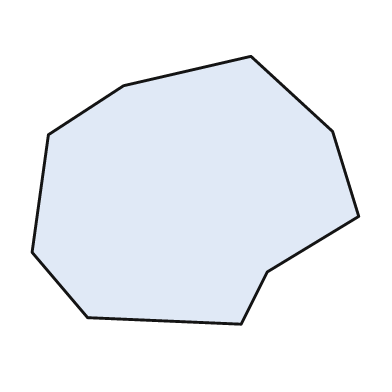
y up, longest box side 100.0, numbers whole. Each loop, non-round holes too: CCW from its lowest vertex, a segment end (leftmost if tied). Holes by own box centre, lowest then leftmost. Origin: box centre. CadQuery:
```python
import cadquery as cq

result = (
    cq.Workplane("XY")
    .moveTo(14.0, -41.0)
    .lineTo(22.0, -25.0)
    .lineTo(50.0, -8.0)
    .lineTo(42.0, 18.0)
    .lineTo(17.0, 41.0)
    .lineTo(-22.0, 32.0)
    .lineTo(-45.0, 17.0)
    .lineTo(-50.0, -19.0)
    .lineTo(-33.0, -39.0)
    .close()
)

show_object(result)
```